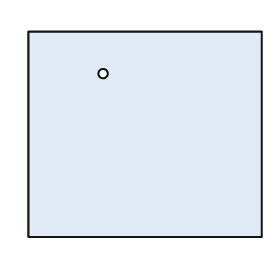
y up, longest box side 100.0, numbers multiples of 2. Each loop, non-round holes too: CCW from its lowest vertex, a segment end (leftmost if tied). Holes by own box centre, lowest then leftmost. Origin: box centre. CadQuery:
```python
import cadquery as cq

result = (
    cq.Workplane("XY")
    .moveTo(-50.0, -44.0)
    .lineTo(50.0, -44.0)
    .lineTo(50.0, 44.0)
    .lineTo(-50.0, 44.0)
    .close()
    .moveTo(-18.0, 26.0)
    .circle(2.0)
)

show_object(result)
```